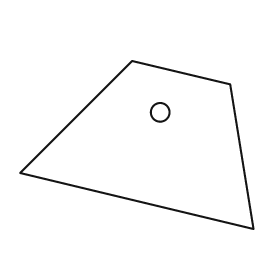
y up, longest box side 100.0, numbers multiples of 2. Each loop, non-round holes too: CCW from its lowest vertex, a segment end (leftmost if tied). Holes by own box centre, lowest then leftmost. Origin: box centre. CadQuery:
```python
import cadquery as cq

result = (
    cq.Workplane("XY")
    .moveTo(50.0, -36.0)
    .lineTo(40.0, 26.0)
    .lineTo(-2.0, 36.0)
    .lineTo(-50.0, -12.0)
    .close()
    .moveTo(10.0, 14.0)
    .circle(4.0)
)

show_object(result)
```